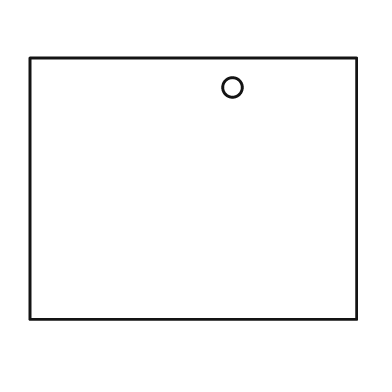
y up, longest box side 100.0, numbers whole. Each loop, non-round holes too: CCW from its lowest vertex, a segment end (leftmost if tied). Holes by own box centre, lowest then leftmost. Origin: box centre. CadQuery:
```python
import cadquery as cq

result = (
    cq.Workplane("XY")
    .moveTo(-50.0, -40.0)
    .lineTo(50.0, -40.0)
    .lineTo(50.0, 40.0)
    .lineTo(-50.0, 40.0)
    .close()
    .moveTo(12.0, 31.0)
    .circle(3.0)
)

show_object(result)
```